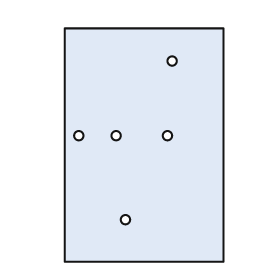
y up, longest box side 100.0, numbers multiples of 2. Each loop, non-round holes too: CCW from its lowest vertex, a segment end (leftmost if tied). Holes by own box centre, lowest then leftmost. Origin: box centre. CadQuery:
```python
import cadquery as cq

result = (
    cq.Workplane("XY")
    .moveTo(-34.0, -50.0)
    .lineTo(34.0, -50.0)
    .lineTo(34.0, 50.0)
    .lineTo(-34.0, 50.0)
    .close()
    .moveTo(-8.0, -32.0)
    .circle(2.0)
    .moveTo(-28.0, 4.0)
    .circle(2.0)
    .moveTo(-12.0, 4.0)
    .circle(2.0)
    .moveTo(10.0, 4.0)
    .circle(2.0)
    .moveTo(12.0, 36.0)
    .circle(2.0)
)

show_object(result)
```